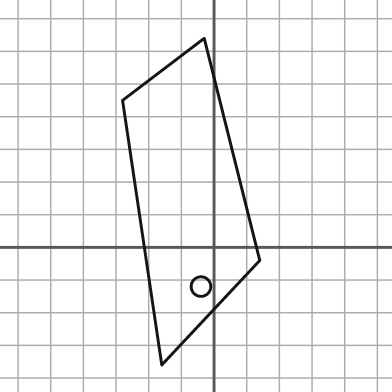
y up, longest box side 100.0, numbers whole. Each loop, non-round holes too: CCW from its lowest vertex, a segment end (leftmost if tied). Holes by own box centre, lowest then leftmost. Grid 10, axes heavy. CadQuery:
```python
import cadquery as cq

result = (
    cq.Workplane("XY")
    .moveTo(-16.0, -36.0)
    .lineTo(14.0, -4.0)
    .lineTo(-3.0, 64.0)
    .lineTo(-28.0, 45.0)
    .close()
    .moveTo(-4.0, -12.0)
    .circle(3.0)
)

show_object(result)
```